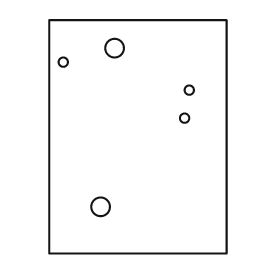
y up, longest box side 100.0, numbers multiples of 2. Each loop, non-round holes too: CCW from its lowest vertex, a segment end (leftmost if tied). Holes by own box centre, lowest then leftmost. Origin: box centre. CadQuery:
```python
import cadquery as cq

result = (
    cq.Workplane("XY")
    .moveTo(-38.0, -50.0)
    .lineTo(38.0, -50.0)
    .lineTo(38.0, 50.0)
    .lineTo(-38.0, 50.0)
    .close()
    .moveTo(-16.0, -30.0)
    .circle(4.0)
    .moveTo(20.0, 8.0)
    .circle(2.0)
    .moveTo(22.0, 20.0)
    .circle(2.0)
    .moveTo(-32.0, 32.0)
    .circle(2.0)
    .moveTo(-10.0, 38.0)
    .circle(4.0)
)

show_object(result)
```